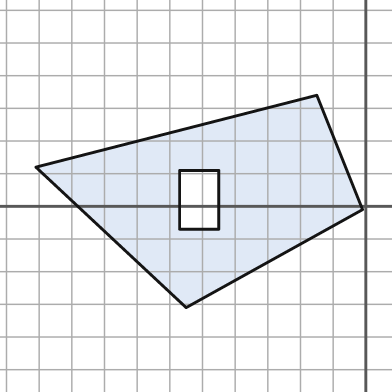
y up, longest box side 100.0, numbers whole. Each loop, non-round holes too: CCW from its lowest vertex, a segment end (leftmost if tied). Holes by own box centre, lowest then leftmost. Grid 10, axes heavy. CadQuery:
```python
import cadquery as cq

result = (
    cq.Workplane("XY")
    .moveTo(-55.0, -31.0)
    .lineTo(-1.0, -1.0)
    .lineTo(-15.0, 34.0)
    .lineTo(-101.0, 12.0)
    .close()
    .moveTo(-57.0, -7.0)
    .lineTo(-45.0, -7.0)
    .lineTo(-45.0, 11.0)
    .lineTo(-57.0, 11.0)
    .close()
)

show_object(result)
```